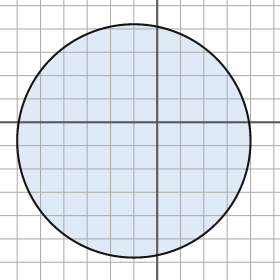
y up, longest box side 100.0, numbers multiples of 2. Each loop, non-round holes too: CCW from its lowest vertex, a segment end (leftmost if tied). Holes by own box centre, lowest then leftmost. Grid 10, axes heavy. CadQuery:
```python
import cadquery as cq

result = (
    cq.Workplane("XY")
    .moveTo(-10.0, -8.0)
    .circle(50.0)
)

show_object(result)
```